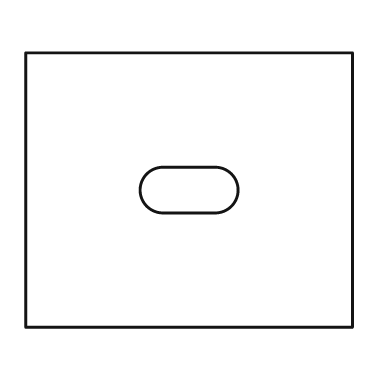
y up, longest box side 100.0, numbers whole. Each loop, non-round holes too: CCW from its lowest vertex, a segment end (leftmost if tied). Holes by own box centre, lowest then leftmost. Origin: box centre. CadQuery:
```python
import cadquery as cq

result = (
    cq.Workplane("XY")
    .moveTo(-50.0, -42.0)
    .lineTo(50.0, -42.0)
    .lineTo(50.0, 42.0)
    .lineTo(-50.0, 42.0)
    .close()
    .moveTo(-8.0, -7.0)
    .lineTo(8.0, -7.0)
    .threePointArc((15.0, 0.0), (8.0, 7.0))
    .lineTo(-8.0, 7.0)
    .threePointArc((-15.0, 0.0), (-8.0, -7.0))
    .close()
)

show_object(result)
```